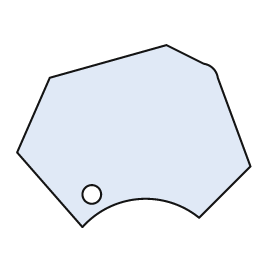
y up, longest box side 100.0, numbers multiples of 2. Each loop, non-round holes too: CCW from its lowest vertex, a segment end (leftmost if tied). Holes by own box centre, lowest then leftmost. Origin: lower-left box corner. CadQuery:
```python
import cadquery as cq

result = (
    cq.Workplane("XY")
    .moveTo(28.0, 0.0)
    .threePointArc((52.0, 12.0), (78.0, 4.0))
    .lineTo(100.0, 26.0)
    .lineTo(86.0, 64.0)
    .threePointArc((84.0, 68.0), (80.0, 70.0))
    .lineTo(64.0, 78.0)
    .lineTo(14.0, 64.0)
    .lineTo(0.0, 32.0)
    .close()
    .moveTo(32.0, 14.0)
    .circle(4.0)
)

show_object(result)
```